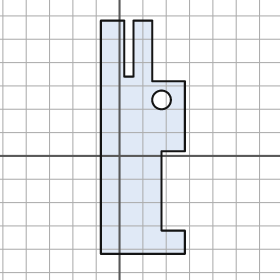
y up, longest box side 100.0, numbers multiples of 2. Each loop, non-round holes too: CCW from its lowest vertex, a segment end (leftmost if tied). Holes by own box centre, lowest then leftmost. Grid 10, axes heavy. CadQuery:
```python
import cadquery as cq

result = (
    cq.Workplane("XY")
    .moveTo(-8.0, -42.0)
    .lineTo(28.0, -42.0)
    .lineTo(28.0, -32.0)
    .lineTo(18.0, -32.0)
    .lineTo(18.0, 2.0)
    .lineTo(28.0, 2.0)
    .lineTo(28.0, 32.0)
    .lineTo(14.0, 32.0)
    .lineTo(14.0, 58.0)
    .lineTo(6.0, 58.0)
    .lineTo(6.0, 34.0)
    .lineTo(2.0, 34.0)
    .lineTo(2.0, 58.0)
    .lineTo(-8.0, 58.0)
    .close()
    .moveTo(18.0, 24.0)
    .circle(4.0)
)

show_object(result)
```